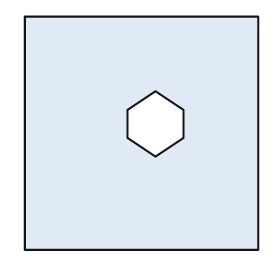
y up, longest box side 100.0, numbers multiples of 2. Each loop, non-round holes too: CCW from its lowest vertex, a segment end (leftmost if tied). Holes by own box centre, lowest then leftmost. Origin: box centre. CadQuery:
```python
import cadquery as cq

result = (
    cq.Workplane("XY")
    .moveTo(-50.0, -50.0)
    .lineTo(50.0, -50.0)
    .lineTo(50.0, 50.0)
    .lineTo(-50.0, 50.0)
    .close()
    .moveTo(6.0, -10.0)
    .lineTo(18.0, -2.0)
    .lineTo(18.0, 10.0)
    .lineTo(6.0, 18.0)
    .lineTo(-6.0, 10.0)
    .lineTo(-6.0, -2.0)
    .close()
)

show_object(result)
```